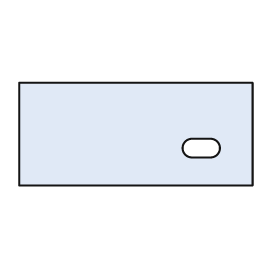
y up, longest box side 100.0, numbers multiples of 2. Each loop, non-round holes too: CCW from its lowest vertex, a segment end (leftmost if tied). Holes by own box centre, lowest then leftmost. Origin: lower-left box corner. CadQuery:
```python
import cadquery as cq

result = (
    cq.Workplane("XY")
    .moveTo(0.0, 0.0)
    .lineTo(100.0, 0.0)
    .lineTo(100.0, 44.0)
    .lineTo(0.0, 44.0)
    .close()
    .moveTo(74.0, 12.0)
    .lineTo(82.0, 12.0)
    .threePointArc((86.0, 16.0), (82.0, 20.0))
    .lineTo(74.0, 20.0)
    .threePointArc((70.0, 16.0), (74.0, 12.0))
    .close()
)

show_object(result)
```